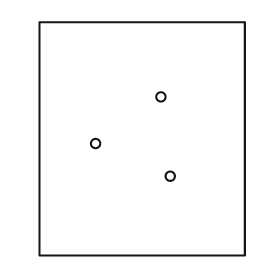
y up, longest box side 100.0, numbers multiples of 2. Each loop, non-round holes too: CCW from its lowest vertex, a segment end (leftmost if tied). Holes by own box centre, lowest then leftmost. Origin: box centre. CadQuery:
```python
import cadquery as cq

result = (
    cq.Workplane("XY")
    .moveTo(-44.0, -50.0)
    .lineTo(44.0, -50.0)
    .lineTo(44.0, 50.0)
    .lineTo(-44.0, 50.0)
    .close()
    .moveTo(12.0, -16.0)
    .circle(2.0)
    .moveTo(-20.0, -2.0)
    .circle(2.0)
    .moveTo(8.0, 18.0)
    .circle(2.0)
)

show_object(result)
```